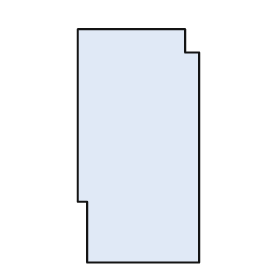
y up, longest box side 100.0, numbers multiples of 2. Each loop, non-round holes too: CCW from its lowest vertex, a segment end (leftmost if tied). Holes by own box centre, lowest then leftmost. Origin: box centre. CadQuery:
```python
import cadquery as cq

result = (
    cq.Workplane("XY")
    .moveTo(-22.0, -50.0)
    .lineTo(26.0, -50.0)
    .lineTo(26.0, 40.0)
    .lineTo(20.0, 40.0)
    .lineTo(20.0, 50.0)
    .lineTo(-26.0, 50.0)
    .lineTo(-26.0, -24.0)
    .lineTo(-22.0, -24.0)
    .close()
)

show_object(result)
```